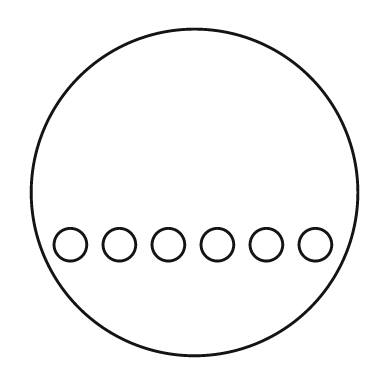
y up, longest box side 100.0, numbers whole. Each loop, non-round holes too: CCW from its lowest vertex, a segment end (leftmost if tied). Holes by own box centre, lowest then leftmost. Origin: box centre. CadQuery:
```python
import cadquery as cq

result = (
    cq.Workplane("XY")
    .moveTo(0.0, 0.0)
    .circle(50.0)
    .moveTo(-38.0, -16.0)
    .circle(5.0)
    .moveTo(-23.0, -16.0)
    .circle(5.0)
    .moveTo(-8.0, -16.0)
    .circle(5.0)
    .moveTo(7.0, -16.0)
    .circle(5.0)
    .moveTo(22.0, -16.0)
    .circle(5.0)
    .moveTo(37.0, -16.0)
    .circle(5.0)
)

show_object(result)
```